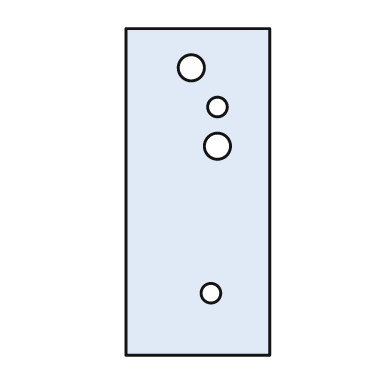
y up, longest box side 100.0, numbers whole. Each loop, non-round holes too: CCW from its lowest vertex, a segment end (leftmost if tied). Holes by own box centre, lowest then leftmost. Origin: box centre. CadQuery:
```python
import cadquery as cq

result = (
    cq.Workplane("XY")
    .moveTo(-22.0, -50.0)
    .lineTo(22.0, -50.0)
    .lineTo(22.0, 50.0)
    .lineTo(-22.0, 50.0)
    .close()
    .moveTo(4.0, -31.0)
    .circle(3.0)
    .moveTo(6.0, 14.0)
    .circle(4.0)
    .moveTo(6.0, 26.0)
    .circle(3.0)
    .moveTo(-2.0, 38.0)
    .circle(4.0)
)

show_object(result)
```